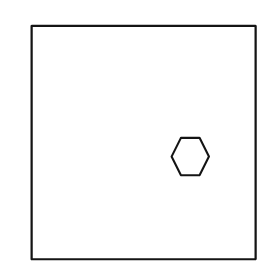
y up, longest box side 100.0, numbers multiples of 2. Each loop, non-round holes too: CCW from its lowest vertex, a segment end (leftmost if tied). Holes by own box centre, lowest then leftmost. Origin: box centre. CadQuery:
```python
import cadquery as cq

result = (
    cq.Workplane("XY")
    .moveTo(-48.0, -50.0)
    .lineTo(48.0, -50.0)
    .lineTo(48.0, 50.0)
    .lineTo(-48.0, 50.0)
    .close()
    .moveTo(16.0, -14.0)
    .lineTo(24.0, -14.0)
    .lineTo(28.0, -6.0)
    .lineTo(24.0, 2.0)
    .lineTo(16.0, 2.0)
    .lineTo(12.0, -6.0)
    .close()
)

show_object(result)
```